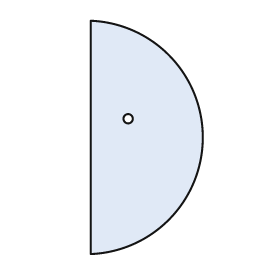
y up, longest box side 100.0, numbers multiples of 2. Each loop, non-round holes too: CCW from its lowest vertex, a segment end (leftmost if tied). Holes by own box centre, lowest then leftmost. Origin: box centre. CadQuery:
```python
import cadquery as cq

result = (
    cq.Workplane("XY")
    .moveTo(-24.0, -50.0)
    .threePointArc((24.0, 0.0), (-24.0, 50.0))
    .close()
    .moveTo(-8.0, 8.0)
    .circle(2.0)
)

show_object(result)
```